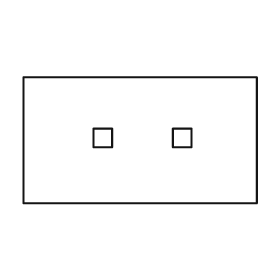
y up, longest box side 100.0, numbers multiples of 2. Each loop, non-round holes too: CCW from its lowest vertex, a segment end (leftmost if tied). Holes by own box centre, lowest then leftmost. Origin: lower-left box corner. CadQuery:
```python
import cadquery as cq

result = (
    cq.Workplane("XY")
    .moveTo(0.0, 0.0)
    .lineTo(100.0, 0.0)
    .lineTo(100.0, 54.0)
    .lineTo(0.0, 54.0)
    .close()
    .moveTo(30.0, 24.0)
    .lineTo(38.0, 24.0)
    .lineTo(38.0, 32.0)
    .lineTo(30.0, 32.0)
    .close()
    .moveTo(64.0, 24.0)
    .lineTo(72.0, 24.0)
    .lineTo(72.0, 32.0)
    .lineTo(64.0, 32.0)
    .close()
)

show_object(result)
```